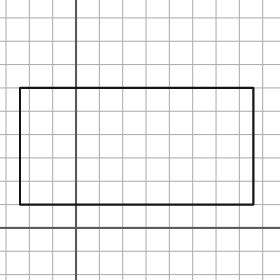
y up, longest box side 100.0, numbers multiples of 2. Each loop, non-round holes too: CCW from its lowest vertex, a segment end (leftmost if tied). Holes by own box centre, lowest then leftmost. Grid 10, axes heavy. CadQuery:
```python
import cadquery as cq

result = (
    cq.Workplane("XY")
    .moveTo(-24.0, 10.0)
    .lineTo(76.0, 10.0)
    .lineTo(76.0, 60.0)
    .lineTo(-24.0, 60.0)
    .close()
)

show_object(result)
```